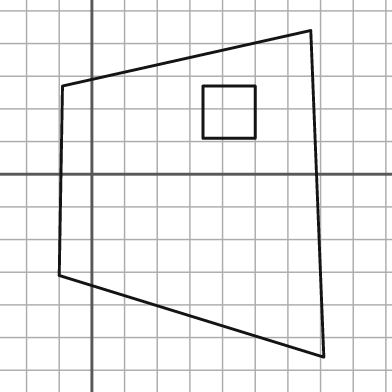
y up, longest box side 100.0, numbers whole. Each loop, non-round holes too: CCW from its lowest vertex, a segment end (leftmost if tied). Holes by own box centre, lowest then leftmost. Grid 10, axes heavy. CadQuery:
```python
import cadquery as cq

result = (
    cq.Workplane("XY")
    .moveTo(71.0, -56.0)
    .lineTo(67.0, 44.0)
    .lineTo(-9.0, 27.0)
    .lineTo(-10.0, -31.0)
    .close()
    .moveTo(34.0, 11.0)
    .lineTo(50.0, 11.0)
    .lineTo(50.0, 27.0)
    .lineTo(34.0, 27.0)
    .close()
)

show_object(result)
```